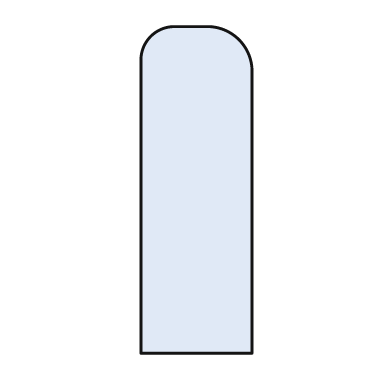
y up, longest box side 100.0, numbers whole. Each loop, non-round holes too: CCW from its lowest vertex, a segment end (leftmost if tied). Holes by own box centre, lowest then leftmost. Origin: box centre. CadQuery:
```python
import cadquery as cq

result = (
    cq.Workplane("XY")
    .moveTo(-17.0, -50.0)
    .lineTo(17.0, -50.0)
    .lineTo(17.0, 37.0)
    .threePointArc((13.0, 46.0), (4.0, 50.0))
    .lineTo(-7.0, 50.0)
    .threePointArc((-14.0, 47.0), (-17.0, 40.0))
    .close()
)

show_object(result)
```